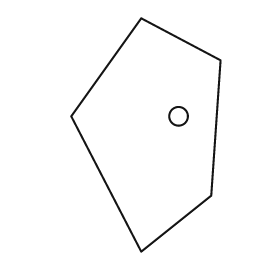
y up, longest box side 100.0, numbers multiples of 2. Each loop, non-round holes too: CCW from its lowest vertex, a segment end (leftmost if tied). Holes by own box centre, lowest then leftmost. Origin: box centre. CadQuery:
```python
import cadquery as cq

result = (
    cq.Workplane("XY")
    .moveTo(-2.0, -50.0)
    .lineTo(28.0, -26.0)
    .lineTo(32.0, 32.0)
    .lineTo(-2.0, 50.0)
    .lineTo(-32.0, 8.0)
    .close()
    .moveTo(14.0, 8.0)
    .circle(4.0)
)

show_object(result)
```